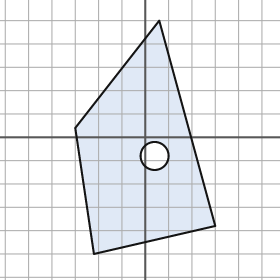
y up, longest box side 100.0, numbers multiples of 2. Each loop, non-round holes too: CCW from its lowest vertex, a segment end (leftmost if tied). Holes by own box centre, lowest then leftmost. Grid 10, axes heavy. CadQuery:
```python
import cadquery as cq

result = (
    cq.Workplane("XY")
    .moveTo(-22.0, -50.0)
    .lineTo(30.0, -38.0)
    .lineTo(6.0, 50.0)
    .lineTo(-30.0, 4.0)
    .close()
    .moveTo(4.0, -8.0)
    .circle(6.0)
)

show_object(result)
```